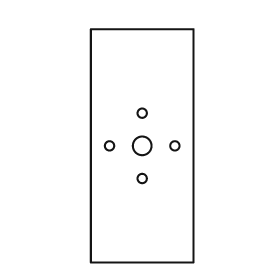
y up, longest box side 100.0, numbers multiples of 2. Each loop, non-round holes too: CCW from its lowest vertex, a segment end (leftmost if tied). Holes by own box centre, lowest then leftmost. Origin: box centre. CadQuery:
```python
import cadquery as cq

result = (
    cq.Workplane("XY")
    .moveTo(-22.0, -50.0)
    .lineTo(22.0, -50.0)
    .lineTo(22.0, 50.0)
    .lineTo(-22.0, 50.0)
    .close()
    .moveTo(0.0, -14.0)
    .circle(2.0)
    .moveTo(-14.0, 0.0)
    .circle(2.0)
    .moveTo(0.0, 0.0)
    .circle(4.0)
    .moveTo(14.0, 0.0)
    .circle(2.0)
    .moveTo(0.0, 14.0)
    .circle(2.0)
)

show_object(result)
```